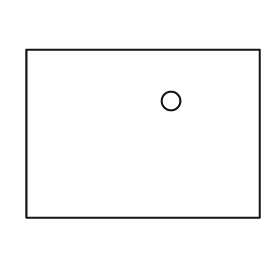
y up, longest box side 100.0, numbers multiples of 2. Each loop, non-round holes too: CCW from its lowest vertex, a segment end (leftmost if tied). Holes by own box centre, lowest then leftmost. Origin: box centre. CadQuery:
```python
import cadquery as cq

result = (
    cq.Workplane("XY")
    .moveTo(-50.0, -36.0)
    .lineTo(50.0, -36.0)
    .lineTo(50.0, 36.0)
    .lineTo(-50.0, 36.0)
    .close()
    .moveTo(12.0, 14.0)
    .circle(4.0)
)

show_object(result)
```